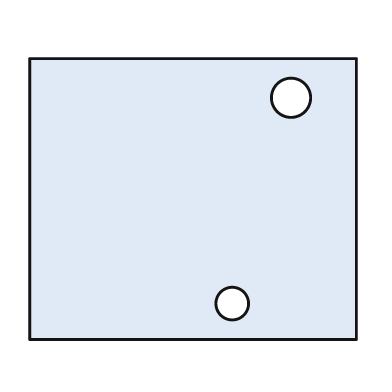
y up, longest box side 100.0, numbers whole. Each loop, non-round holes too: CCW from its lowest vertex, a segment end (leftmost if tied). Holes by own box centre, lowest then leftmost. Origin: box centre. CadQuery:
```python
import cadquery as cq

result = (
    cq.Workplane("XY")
    .moveTo(-50.0, -43.0)
    .lineTo(50.0, -43.0)
    .lineTo(50.0, 43.0)
    .lineTo(-50.0, 43.0)
    .close()
    .moveTo(12.0, -32.0)
    .circle(5.0)
    .moveTo(30.0, 31.0)
    .circle(6.0)
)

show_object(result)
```